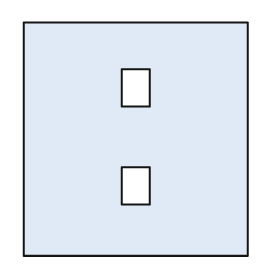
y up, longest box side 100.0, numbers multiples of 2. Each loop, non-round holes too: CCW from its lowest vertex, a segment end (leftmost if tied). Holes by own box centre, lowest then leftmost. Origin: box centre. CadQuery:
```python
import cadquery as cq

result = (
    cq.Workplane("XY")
    .moveTo(-48.0, -50.0)
    .lineTo(48.0, -50.0)
    .lineTo(48.0, 50.0)
    .lineTo(-48.0, 50.0)
    .close()
    .moveTo(-6.0, -28.0)
    .lineTo(6.0, -28.0)
    .lineTo(6.0, -12.0)
    .lineTo(-6.0, -12.0)
    .close()
    .moveTo(-6.0, 14.0)
    .lineTo(6.0, 14.0)
    .lineTo(6.0, 30.0)
    .lineTo(-6.0, 30.0)
    .close()
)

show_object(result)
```